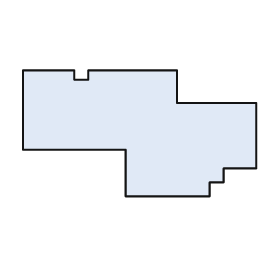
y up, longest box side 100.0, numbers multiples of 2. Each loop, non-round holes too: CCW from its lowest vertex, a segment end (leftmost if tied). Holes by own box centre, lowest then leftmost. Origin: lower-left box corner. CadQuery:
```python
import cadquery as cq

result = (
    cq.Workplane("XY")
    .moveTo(44.0, 0.0)
    .lineTo(80.0, 0.0)
    .lineTo(80.0, 6.0)
    .lineTo(86.0, 6.0)
    .lineTo(86.0, 12.0)
    .lineTo(100.0, 12.0)
    .lineTo(100.0, 40.0)
    .lineTo(66.0, 40.0)
    .lineTo(66.0, 54.0)
    .lineTo(28.0, 54.0)
    .lineTo(28.0, 50.0)
    .lineTo(22.0, 50.0)
    .lineTo(22.0, 54.0)
    .lineTo(0.0, 54.0)
    .lineTo(0.0, 20.0)
    .lineTo(44.0, 20.0)
    .close()
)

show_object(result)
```